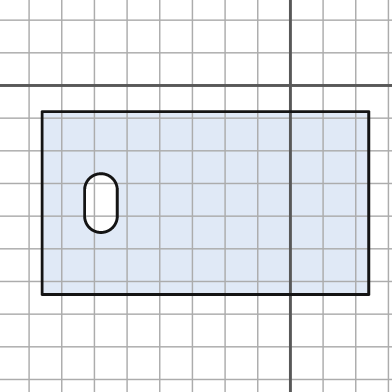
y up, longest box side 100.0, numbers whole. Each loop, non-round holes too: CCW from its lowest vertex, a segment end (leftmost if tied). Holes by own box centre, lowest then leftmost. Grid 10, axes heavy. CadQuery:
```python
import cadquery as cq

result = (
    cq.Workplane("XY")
    .moveTo(-76.0, -64.0)
    .lineTo(24.0, -64.0)
    .lineTo(24.0, -8.0)
    .lineTo(-76.0, -8.0)
    .close()
    .moveTo(-63.0, -40.0)
    .threePointArc((-58.0, -45.0), (-53.0, -40.0))
    .lineTo(-53.0, -32.0)
    .threePointArc((-58.0, -27.0), (-63.0, -32.0))
    .close()
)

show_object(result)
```